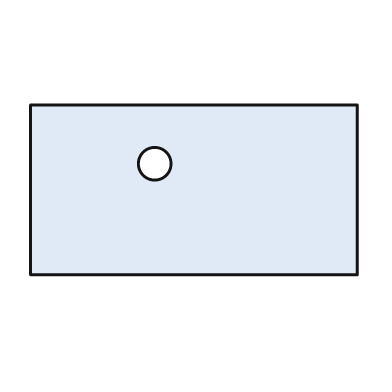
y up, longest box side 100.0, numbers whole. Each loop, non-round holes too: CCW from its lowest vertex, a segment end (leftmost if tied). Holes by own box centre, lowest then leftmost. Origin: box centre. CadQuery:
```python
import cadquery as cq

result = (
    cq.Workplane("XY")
    .moveTo(-50.0, -26.0)
    .lineTo(50.0, -26.0)
    .lineTo(50.0, 26.0)
    .lineTo(-50.0, 26.0)
    .close()
    .moveTo(-12.0, 8.0)
    .circle(5.0)
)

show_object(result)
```